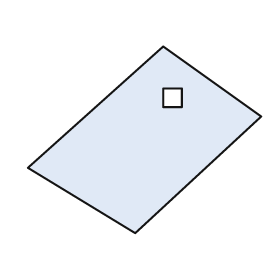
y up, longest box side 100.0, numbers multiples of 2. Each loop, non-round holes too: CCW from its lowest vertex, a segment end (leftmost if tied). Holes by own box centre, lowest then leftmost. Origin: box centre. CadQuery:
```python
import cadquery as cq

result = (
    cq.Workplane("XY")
    .moveTo(-4.0, -40.0)
    .lineTo(50.0, 10.0)
    .lineTo(8.0, 40.0)
    .lineTo(-50.0, -12.0)
    .close()
    .moveTo(8.0, 14.0)
    .lineTo(16.0, 14.0)
    .lineTo(16.0, 22.0)
    .lineTo(8.0, 22.0)
    .close()
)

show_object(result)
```